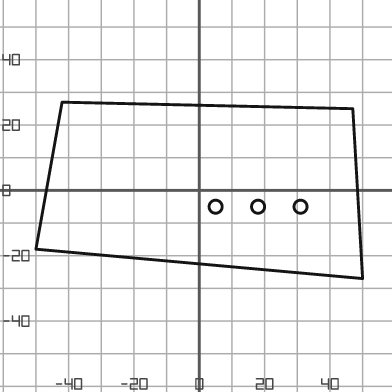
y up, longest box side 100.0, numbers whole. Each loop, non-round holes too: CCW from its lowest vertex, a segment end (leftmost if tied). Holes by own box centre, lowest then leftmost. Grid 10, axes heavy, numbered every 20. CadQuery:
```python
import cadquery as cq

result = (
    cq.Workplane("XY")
    .moveTo(50.0, -27.0)
    .lineTo(47.0, 25.0)
    .lineTo(-42.0, 27.0)
    .lineTo(-50.0, -18.0)
    .close()
    .moveTo(5.0, -5.0)
    .circle(2.0)
    .moveTo(18.0, -5.0)
    .circle(2.0)
    .moveTo(31.0, -5.0)
    .circle(2.0)
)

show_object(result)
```